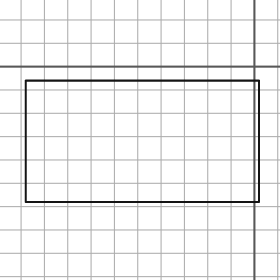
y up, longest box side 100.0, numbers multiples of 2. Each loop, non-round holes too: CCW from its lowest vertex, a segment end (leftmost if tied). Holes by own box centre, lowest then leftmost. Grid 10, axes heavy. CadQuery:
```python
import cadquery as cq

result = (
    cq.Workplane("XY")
    .moveTo(-98.0, -58.0)
    .lineTo(2.0, -58.0)
    .lineTo(2.0, -6.0)
    .lineTo(-98.0, -6.0)
    .close()
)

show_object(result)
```